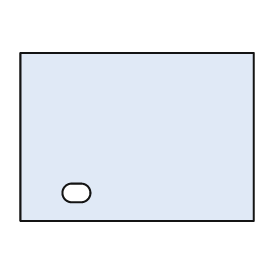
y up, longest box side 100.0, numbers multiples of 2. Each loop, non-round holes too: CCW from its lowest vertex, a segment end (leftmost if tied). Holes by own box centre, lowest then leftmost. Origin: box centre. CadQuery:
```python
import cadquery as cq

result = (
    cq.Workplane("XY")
    .moveTo(-50.0, -36.0)
    .lineTo(50.0, -36.0)
    .lineTo(50.0, 36.0)
    .lineTo(-50.0, 36.0)
    .close()
    .moveTo(-28.0, -28.0)
    .lineTo(-24.0, -28.0)
    .threePointArc((-20.0, -24.0), (-24.0, -20.0))
    .lineTo(-28.0, -20.0)
    .threePointArc((-32.0, -24.0), (-28.0, -28.0))
    .close()
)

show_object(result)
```